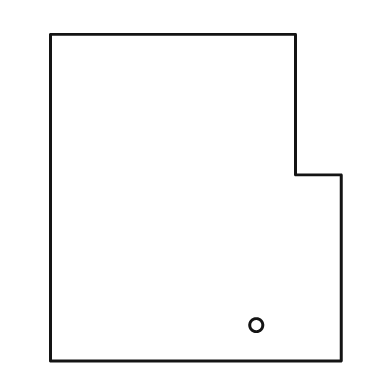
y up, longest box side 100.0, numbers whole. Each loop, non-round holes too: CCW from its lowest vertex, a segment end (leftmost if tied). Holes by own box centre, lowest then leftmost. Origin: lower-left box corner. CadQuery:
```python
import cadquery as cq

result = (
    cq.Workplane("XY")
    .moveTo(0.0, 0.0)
    .lineTo(89.0, 0.0)
    .lineTo(89.0, 57.0)
    .lineTo(75.0, 57.0)
    .lineTo(75.0, 100.0)
    .lineTo(0.0, 100.0)
    .close()
    .moveTo(63.0, 11.0)
    .circle(2.0)
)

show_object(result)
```